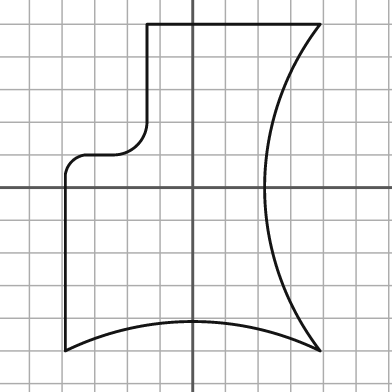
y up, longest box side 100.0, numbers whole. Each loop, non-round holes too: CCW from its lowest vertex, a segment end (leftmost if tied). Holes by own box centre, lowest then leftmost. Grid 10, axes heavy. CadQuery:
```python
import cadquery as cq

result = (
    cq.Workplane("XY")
    .moveTo(-39.0, -50.0)
    .threePointArc((0.0, -41.0), (39.0, -50.0))
    .threePointArc((22.0, 0.0), (39.0, 50.0))
    .lineTo(-14.0, 50.0)
    .lineTo(-14.0, 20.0)
    .threePointArc((-17.0, 13.0), (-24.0, 10.0))
    .lineTo(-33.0, 10.0)
    .threePointArc((-37.0, 8.0), (-39.0, 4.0))
    .close()
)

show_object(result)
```